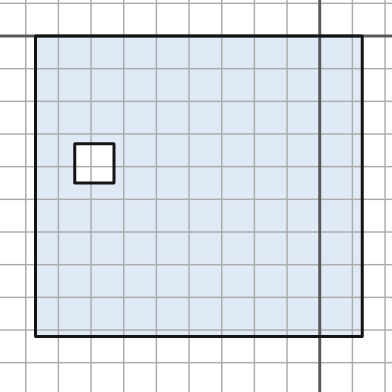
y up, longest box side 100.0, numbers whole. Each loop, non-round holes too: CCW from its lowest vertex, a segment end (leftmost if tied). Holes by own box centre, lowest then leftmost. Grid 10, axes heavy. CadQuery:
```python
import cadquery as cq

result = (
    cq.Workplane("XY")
    .moveTo(-87.0, -92.0)
    .lineTo(13.0, -92.0)
    .lineTo(13.0, 0.0)
    .lineTo(-87.0, 0.0)
    .close()
    .moveTo(-75.0, -45.0)
    .lineTo(-63.0, -45.0)
    .lineTo(-63.0, -33.0)
    .lineTo(-75.0, -33.0)
    .close()
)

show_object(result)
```